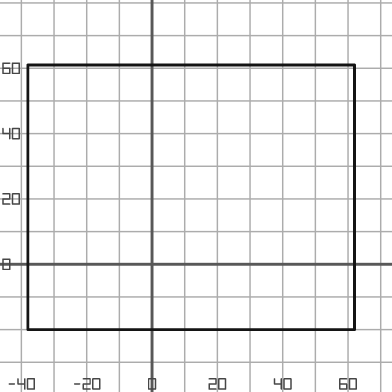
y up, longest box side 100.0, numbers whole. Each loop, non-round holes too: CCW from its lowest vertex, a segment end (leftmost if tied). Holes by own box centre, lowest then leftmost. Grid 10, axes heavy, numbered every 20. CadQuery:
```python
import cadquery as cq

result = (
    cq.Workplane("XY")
    .moveTo(-38.0, -20.0)
    .lineTo(62.0, -20.0)
    .lineTo(62.0, 61.0)
    .lineTo(-38.0, 61.0)
    .close()
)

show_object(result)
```